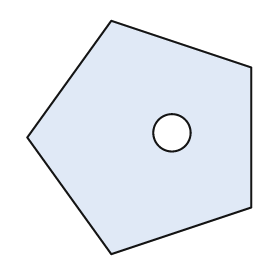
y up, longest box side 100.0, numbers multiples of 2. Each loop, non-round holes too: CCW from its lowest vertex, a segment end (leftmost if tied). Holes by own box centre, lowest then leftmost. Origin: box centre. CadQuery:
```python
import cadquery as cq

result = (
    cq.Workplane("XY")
    .moveTo(-12.0, -50.0)
    .lineTo(48.0, -30.0)
    .lineTo(48.0, 30.0)
    .lineTo(-12.0, 50.0)
    .lineTo(-48.0, 0.0)
    .close()
    .moveTo(14.0, 2.0)
    .circle(8.0)
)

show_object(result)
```